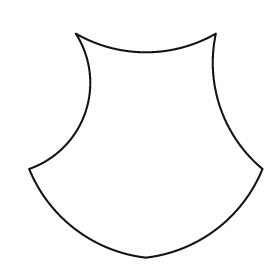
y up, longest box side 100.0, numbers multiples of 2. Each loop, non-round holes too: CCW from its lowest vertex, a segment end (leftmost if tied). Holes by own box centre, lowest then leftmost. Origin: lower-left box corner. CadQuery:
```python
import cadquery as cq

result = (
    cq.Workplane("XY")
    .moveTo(50.0, 0.0)
    .threePointArc((80.0, 12.0), (100.0, 38.0))
    .threePointArc((82.0, 64.0), (80.0, 96.0))
    .threePointArc((50.0, 88.0), (20.0, 96.0))
    .threePointArc((24.0, 62.0), (0.0, 38.0))
    .threePointArc((20.0, 12.0), (50.0, 0.0))
    .close()
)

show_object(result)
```